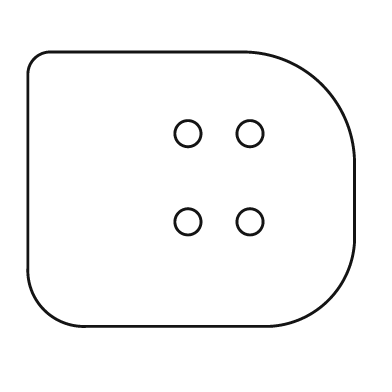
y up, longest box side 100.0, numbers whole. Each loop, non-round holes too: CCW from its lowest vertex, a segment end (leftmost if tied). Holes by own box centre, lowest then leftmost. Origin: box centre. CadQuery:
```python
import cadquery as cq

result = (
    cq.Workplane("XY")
    .moveTo(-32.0, -42.0)
    .lineTo(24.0, -42.0)
    .threePointArc((42.0, -34.0), (50.0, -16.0))
    .lineTo(50.0, 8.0)
    .threePointArc((40.0, 32.0), (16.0, 42.0))
    .lineTo(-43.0, 42.0)
    .threePointArc((-48.0, 40.0), (-50.0, 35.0))
    .lineTo(-50.0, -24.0)
    .threePointArc((-45.0, -37.0), (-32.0, -42.0))
    .close()
    .moveTo(-1.0, -10.0)
    .circle(4.0)
    .moveTo(18.0, -10.0)
    .circle(4.0)
    .moveTo(-1.0, 17.0)
    .circle(4.0)
    .moveTo(18.0, 17.0)
    .circle(4.0)
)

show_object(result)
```